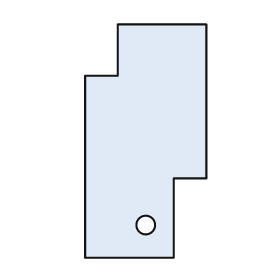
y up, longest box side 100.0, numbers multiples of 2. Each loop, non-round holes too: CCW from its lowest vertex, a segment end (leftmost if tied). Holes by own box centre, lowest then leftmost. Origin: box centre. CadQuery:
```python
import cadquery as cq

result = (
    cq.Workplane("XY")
    .moveTo(-26.0, -50.0)
    .lineTo(12.0, -50.0)
    .lineTo(12.0, -16.0)
    .lineTo(26.0, -16.0)
    .lineTo(26.0, 50.0)
    .lineTo(-12.0, 50.0)
    .lineTo(-12.0, 28.0)
    .lineTo(-26.0, 28.0)
    .close()
    .moveTo(0.0, -36.0)
    .circle(4.0)
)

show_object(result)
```